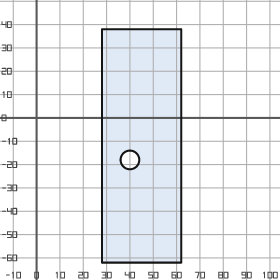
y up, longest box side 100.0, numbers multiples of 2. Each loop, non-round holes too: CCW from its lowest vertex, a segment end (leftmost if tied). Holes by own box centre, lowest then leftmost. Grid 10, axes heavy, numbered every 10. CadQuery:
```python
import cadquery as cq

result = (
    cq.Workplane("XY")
    .moveTo(28.0, -62.0)
    .lineTo(62.0, -62.0)
    .lineTo(62.0, 38.0)
    .lineTo(28.0, 38.0)
    .close()
    .moveTo(40.0, -18.0)
    .circle(4.0)
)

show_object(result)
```